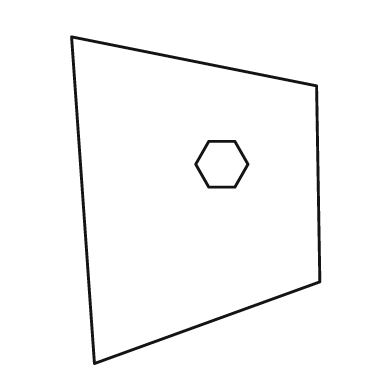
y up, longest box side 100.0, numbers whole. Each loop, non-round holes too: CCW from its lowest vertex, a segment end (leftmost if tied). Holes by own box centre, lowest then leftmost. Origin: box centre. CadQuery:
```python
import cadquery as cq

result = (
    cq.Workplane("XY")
    .moveTo(-31.0, -50.0)
    .lineTo(38.0, -25.0)
    .lineTo(37.0, 35.0)
    .lineTo(-38.0, 50.0)
    .close()
    .moveTo(4.0, 4.0)
    .lineTo(12.0, 4.0)
    .lineTo(16.0, 11.0)
    .lineTo(12.0, 18.0)
    .lineTo(4.0, 18.0)
    .lineTo(0.0, 11.0)
    .close()
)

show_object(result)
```